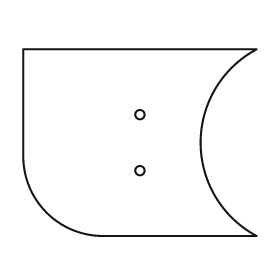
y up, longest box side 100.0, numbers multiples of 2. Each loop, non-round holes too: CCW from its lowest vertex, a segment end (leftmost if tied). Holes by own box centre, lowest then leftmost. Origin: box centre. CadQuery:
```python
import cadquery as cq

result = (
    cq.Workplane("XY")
    .moveTo(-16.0, -40.0)
    .lineTo(50.0, -40.0)
    .threePointArc((26.0, 0.0), (50.0, 40.0))
    .lineTo(-50.0, 40.0)
    .lineTo(-50.0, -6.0)
    .threePointArc((-40.0, -30.0), (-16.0, -40.0))
    .close()
    .moveTo(0.0, -12.0)
    .circle(2.0)
    .moveTo(0.0, 12.0)
    .circle(2.0)
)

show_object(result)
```